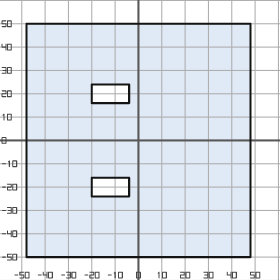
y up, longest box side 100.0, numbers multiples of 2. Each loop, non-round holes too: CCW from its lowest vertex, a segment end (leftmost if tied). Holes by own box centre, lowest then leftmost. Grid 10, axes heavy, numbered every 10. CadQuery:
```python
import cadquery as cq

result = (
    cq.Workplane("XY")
    .moveTo(-48.0, -50.0)
    .lineTo(48.0, -50.0)
    .lineTo(48.0, 50.0)
    .lineTo(-48.0, 50.0)
    .close()
    .moveTo(-20.0, -24.0)
    .lineTo(-4.0, -24.0)
    .lineTo(-4.0, -16.0)
    .lineTo(-20.0, -16.0)
    .close()
    .moveTo(-20.0, 16.0)
    .lineTo(-4.0, 16.0)
    .lineTo(-4.0, 24.0)
    .lineTo(-20.0, 24.0)
    .close()
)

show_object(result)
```